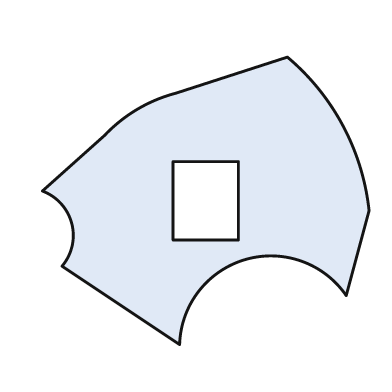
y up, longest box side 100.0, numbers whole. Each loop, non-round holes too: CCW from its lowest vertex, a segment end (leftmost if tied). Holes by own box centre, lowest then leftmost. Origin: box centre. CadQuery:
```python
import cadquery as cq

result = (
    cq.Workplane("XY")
    .moveTo(-8.0, -44.0)
    .threePointArc((12.0, -18.0), (43.0, -29.0))
    .lineTo(50.0, -3.0)
    .threePointArc((42.0, 23.0), (25.0, 44.0))
    .lineTo(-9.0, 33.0)
    .threePointArc((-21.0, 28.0), (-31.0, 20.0))
    .lineTo(-50.0, 3.0)
    .threePointArc((-41.0, -7.0), (-44.0, -20.0))
    .close()
    .moveTo(-10.0, -12.0)
    .lineTo(10.0, -12.0)
    .lineTo(10.0, 12.0)
    .lineTo(-10.0, 12.0)
    .close()
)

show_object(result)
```